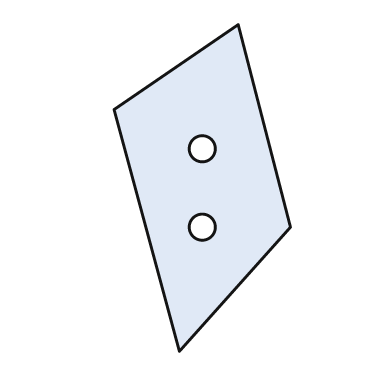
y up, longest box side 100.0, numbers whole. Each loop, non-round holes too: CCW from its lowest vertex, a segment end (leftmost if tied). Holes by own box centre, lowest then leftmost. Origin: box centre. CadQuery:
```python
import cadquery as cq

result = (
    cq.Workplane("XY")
    .moveTo(-7.0, -50.0)
    .lineTo(27.0, -12.0)
    .lineTo(11.0, 50.0)
    .lineTo(-27.0, 24.0)
    .close()
    .moveTo(0.0, -12.0)
    .circle(4.0)
    .moveTo(0.0, 12.0)
    .circle(4.0)
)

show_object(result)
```